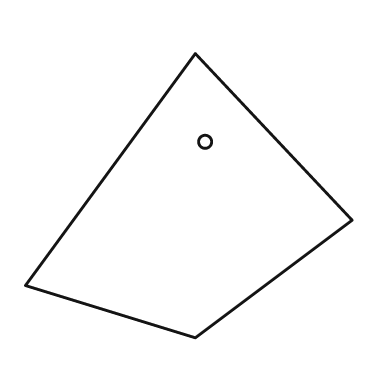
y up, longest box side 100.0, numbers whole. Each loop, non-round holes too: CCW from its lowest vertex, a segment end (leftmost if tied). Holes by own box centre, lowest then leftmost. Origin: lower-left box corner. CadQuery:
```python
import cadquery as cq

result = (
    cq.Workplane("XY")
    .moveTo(52.0, 0.0)
    .lineTo(100.0, 36.0)
    .lineTo(52.0, 87.0)
    .lineTo(0.0, 16.0)
    .close()
    .moveTo(55.0, 60.0)
    .circle(2.0)
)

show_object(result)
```